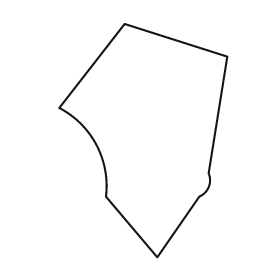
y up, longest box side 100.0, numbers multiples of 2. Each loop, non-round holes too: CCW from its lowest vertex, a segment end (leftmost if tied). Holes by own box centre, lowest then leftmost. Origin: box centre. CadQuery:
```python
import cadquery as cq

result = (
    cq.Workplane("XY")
    .moveTo(6.0, -50.0)
    .lineTo(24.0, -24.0)
    .threePointArc((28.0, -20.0), (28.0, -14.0))
    .lineTo(36.0, 36.0)
    .lineTo(-8.0, 50.0)
    .lineTo(-36.0, 14.0)
    .threePointArc((-20.0, -2.0), (-16.0, -24.0))
    .close()
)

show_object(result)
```